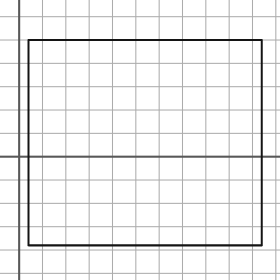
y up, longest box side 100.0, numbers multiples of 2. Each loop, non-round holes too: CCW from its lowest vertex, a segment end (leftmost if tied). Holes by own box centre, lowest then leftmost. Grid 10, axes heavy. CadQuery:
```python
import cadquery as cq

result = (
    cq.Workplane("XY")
    .moveTo(4.0, -38.0)
    .lineTo(104.0, -38.0)
    .lineTo(104.0, 50.0)
    .lineTo(4.0, 50.0)
    .close()
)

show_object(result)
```